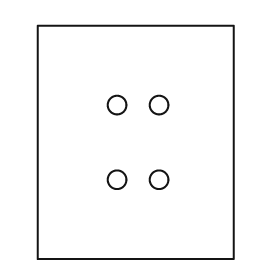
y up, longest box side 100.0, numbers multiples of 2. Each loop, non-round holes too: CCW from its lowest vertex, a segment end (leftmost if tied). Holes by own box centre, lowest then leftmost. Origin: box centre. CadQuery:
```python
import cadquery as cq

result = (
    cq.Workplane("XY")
    .moveTo(-42.0, -50.0)
    .lineTo(42.0, -50.0)
    .lineTo(42.0, 50.0)
    .lineTo(-42.0, 50.0)
    .close()
    .moveTo(-8.0, -16.0)
    .circle(4.0)
    .moveTo(10.0, -16.0)
    .circle(4.0)
    .moveTo(-8.0, 16.0)
    .circle(4.0)
    .moveTo(10.0, 16.0)
    .circle(4.0)
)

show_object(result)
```